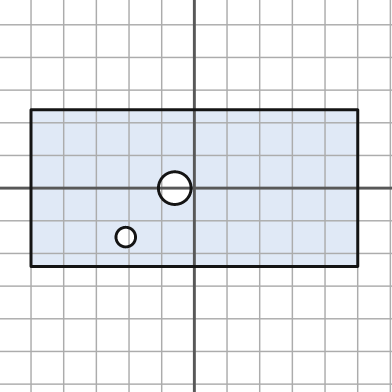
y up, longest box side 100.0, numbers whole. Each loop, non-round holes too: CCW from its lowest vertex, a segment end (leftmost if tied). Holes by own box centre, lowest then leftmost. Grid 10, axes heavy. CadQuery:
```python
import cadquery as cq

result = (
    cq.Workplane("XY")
    .moveTo(-50.0, -24.0)
    .lineTo(50.0, -24.0)
    .lineTo(50.0, 24.0)
    .lineTo(-50.0, 24.0)
    .close()
    .moveTo(-21.0, -15.0)
    .circle(3.0)
    .moveTo(-6.0, 0.0)
    .circle(5.0)
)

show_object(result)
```